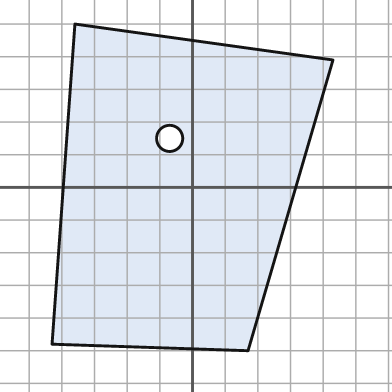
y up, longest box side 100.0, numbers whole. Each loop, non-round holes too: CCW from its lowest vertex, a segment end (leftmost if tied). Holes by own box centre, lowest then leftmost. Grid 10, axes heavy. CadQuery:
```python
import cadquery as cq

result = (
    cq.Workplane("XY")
    .moveTo(17.0, -50.0)
    .lineTo(43.0, 39.0)
    .lineTo(-36.0, 50.0)
    .lineTo(-43.0, -48.0)
    .close()
    .moveTo(-7.0, 15.0)
    .circle(4.0)
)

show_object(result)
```